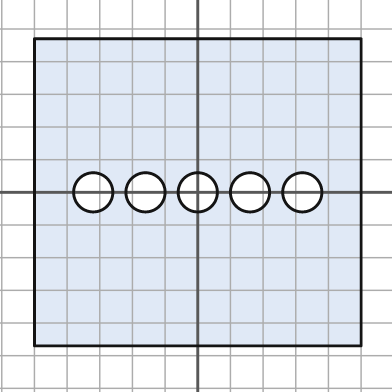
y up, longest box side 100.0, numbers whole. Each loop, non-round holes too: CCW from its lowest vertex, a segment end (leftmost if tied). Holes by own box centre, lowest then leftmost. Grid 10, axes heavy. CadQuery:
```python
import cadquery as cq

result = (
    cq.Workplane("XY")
    .moveTo(-50.0, -47.0)
    .lineTo(50.0, -47.0)
    .lineTo(50.0, 47.0)
    .lineTo(-50.0, 47.0)
    .close()
    .moveTo(-32.0, 0.0)
    .circle(6.0)
    .moveTo(-16.0, 0.0)
    .circle(6.0)
    .moveTo(0.0, 0.0)
    .circle(6.0)
    .moveTo(16.0, 0.0)
    .circle(6.0)
    .moveTo(32.0, 0.0)
    .circle(6.0)
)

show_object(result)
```